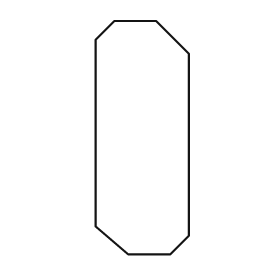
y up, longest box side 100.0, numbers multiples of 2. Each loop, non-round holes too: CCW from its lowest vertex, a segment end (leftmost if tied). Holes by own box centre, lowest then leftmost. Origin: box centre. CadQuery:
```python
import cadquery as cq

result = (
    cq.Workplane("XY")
    .moveTo(-6.0, -50.0)
    .lineTo(12.0, -50.0)
    .lineTo(20.0, -42.0)
    .lineTo(20.0, 36.0)
    .lineTo(6.0, 50.0)
    .lineTo(-12.0, 50.0)
    .lineTo(-20.0, 42.0)
    .lineTo(-20.0, -38.0)
    .close()
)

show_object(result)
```